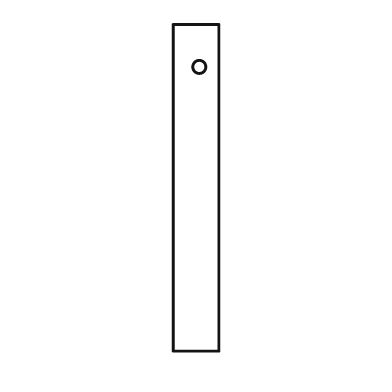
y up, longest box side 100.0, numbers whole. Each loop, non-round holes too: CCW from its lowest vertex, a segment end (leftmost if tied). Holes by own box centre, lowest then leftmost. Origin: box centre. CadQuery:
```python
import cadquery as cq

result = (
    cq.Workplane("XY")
    .moveTo(-7.0, -50.0)
    .lineTo(7.0, -50.0)
    .lineTo(7.0, 50.0)
    .lineTo(-7.0, 50.0)
    .close()
    .moveTo(1.0, 37.0)
    .circle(2.0)
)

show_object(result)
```